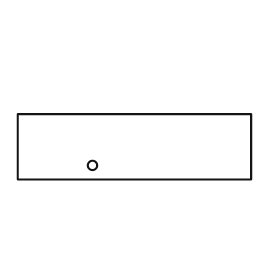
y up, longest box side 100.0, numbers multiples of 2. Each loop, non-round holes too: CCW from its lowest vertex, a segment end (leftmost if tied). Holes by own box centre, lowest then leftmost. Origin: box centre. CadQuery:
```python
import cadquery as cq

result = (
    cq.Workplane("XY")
    .moveTo(-50.0, -14.0)
    .lineTo(50.0, -14.0)
    .lineTo(50.0, 14.0)
    .lineTo(-50.0, 14.0)
    .close()
    .moveTo(-18.0, -8.0)
    .circle(2.0)
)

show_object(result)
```